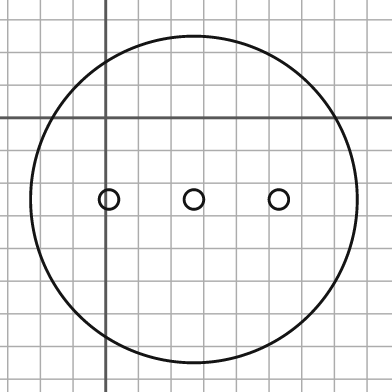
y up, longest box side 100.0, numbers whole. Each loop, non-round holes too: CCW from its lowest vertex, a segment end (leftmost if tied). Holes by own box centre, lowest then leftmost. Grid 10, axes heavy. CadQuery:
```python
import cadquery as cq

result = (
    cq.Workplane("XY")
    .moveTo(27.0, -25.0)
    .circle(50.0)
    .moveTo(1.0, -25.0)
    .circle(3.0)
    .moveTo(27.0, -25.0)
    .circle(3.0)
    .moveTo(53.0, -25.0)
    .circle(3.0)
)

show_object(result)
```